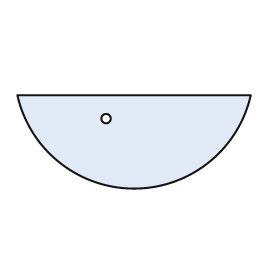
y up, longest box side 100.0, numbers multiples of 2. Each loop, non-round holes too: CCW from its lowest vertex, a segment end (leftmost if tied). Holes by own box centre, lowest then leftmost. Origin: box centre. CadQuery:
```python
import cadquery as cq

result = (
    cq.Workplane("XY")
    .moveTo(-50.0, 20.0)
    .threePointArc((0.0, -20.0), (50.0, 20.0))
    .close()
    .moveTo(-12.0, 10.0)
    .circle(2.0)
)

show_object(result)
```